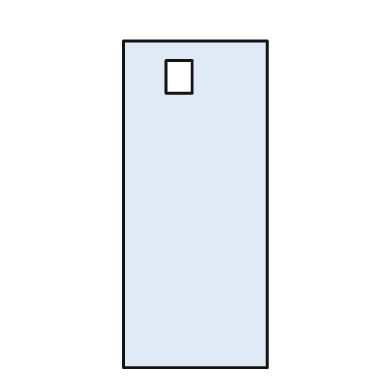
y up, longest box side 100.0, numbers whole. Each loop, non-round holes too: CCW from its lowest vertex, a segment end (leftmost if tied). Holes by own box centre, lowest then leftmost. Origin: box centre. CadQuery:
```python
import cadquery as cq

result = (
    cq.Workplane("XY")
    .moveTo(-22.0, -50.0)
    .lineTo(22.0, -50.0)
    .lineTo(22.0, 50.0)
    .lineTo(-22.0, 50.0)
    .close()
    .moveTo(-9.0, 34.0)
    .lineTo(-1.0, 34.0)
    .lineTo(-1.0, 44.0)
    .lineTo(-9.0, 44.0)
    .close()
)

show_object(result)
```